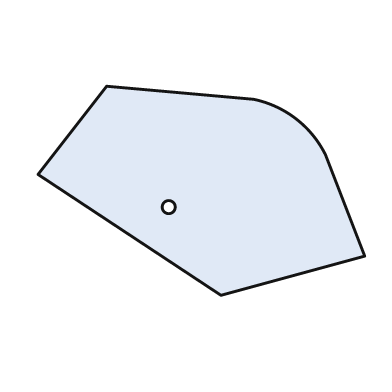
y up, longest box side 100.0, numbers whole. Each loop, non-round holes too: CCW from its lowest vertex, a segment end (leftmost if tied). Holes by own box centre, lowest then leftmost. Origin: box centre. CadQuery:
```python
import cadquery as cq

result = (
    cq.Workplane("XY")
    .moveTo(6.0, -32.0)
    .lineTo(50.0, -20.0)
    .lineTo(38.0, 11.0)
    .threePointArc((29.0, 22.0), (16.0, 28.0))
    .lineTo(-29.0, 32.0)
    .lineTo(-50.0, 5.0)
    .close()
    .moveTo(-10.0, -5.0)
    .circle(2.0)
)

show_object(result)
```